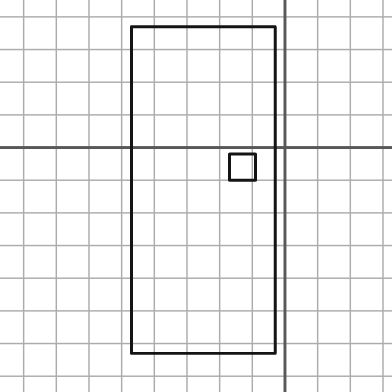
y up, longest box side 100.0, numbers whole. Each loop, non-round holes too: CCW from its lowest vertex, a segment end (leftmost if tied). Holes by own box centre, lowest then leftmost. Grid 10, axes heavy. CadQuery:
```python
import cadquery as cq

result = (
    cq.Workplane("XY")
    .moveTo(-47.0, -63.0)
    .lineTo(-3.0, -63.0)
    .lineTo(-3.0, 37.0)
    .lineTo(-47.0, 37.0)
    .close()
    .moveTo(-17.0, -10.0)
    .lineTo(-9.0, -10.0)
    .lineTo(-9.0, -2.0)
    .lineTo(-17.0, -2.0)
    .close()
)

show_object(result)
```